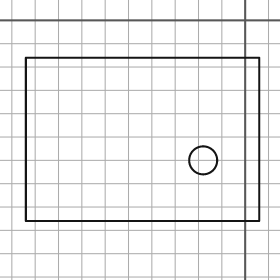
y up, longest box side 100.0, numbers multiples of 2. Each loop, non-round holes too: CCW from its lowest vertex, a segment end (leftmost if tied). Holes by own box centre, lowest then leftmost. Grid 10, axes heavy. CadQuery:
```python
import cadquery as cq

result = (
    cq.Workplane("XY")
    .moveTo(-94.0, -86.0)
    .lineTo(6.0, -86.0)
    .lineTo(6.0, -16.0)
    .lineTo(-94.0, -16.0)
    .close()
    .moveTo(-18.0, -60.0)
    .circle(6.0)
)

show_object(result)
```